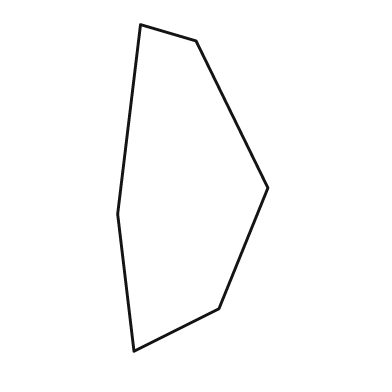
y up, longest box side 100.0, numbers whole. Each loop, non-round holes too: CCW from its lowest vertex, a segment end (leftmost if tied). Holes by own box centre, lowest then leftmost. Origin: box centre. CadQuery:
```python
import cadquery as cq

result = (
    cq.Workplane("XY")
    .moveTo(-18.0, -50.0)
    .lineTo(8.0, -37.0)
    .lineTo(23.0, 0.0)
    .lineTo(1.0, 45.0)
    .lineTo(-16.0, 50.0)
    .lineTo(-23.0, -8.0)
    .close()
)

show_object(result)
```